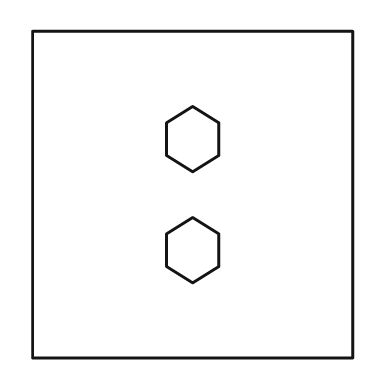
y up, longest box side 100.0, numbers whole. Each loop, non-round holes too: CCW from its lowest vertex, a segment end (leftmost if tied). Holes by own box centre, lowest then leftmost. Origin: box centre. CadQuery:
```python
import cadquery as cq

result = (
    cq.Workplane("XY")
    .moveTo(-49.0, -50.0)
    .lineTo(49.0, -50.0)
    .lineTo(49.0, 50.0)
    .lineTo(-49.0, 50.0)
    .close()
    .moveTo(0.0, -27.0)
    .lineTo(8.0, -22.0)
    .lineTo(8.0, -12.0)
    .lineTo(0.0, -7.0)
    .lineTo(-8.0, -12.0)
    .lineTo(-8.0, -22.0)
    .close()
    .moveTo(0.0, 7.0)
    .lineTo(8.0, 12.0)
    .lineTo(8.0, 22.0)
    .lineTo(0.0, 27.0)
    .lineTo(-8.0, 22.0)
    .lineTo(-8.0, 12.0)
    .close()
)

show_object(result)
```